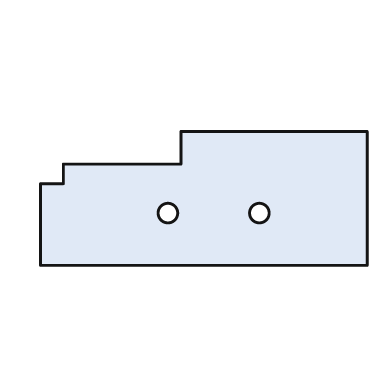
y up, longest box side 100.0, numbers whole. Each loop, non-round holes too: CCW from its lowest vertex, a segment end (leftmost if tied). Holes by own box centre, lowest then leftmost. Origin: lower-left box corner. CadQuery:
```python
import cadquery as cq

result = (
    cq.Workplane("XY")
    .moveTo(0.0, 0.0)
    .lineTo(100.0, 0.0)
    .lineTo(100.0, 41.0)
    .lineTo(43.0, 41.0)
    .lineTo(43.0, 31.0)
    .lineTo(7.0, 31.0)
    .lineTo(7.0, 25.0)
    .lineTo(0.0, 25.0)
    .close()
    .moveTo(39.0, 16.0)
    .circle(3.0)
    .moveTo(67.0, 16.0)
    .circle(3.0)
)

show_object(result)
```